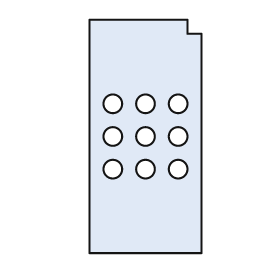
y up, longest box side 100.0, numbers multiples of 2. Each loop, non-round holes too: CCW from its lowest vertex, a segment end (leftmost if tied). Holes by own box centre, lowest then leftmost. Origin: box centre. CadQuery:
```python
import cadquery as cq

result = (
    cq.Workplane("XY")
    .moveTo(-24.0, -50.0)
    .lineTo(24.0, -50.0)
    .lineTo(24.0, 44.0)
    .lineTo(18.0, 44.0)
    .lineTo(18.0, 50.0)
    .lineTo(-24.0, 50.0)
    .close()
    .moveTo(-14.0, -14.0)
    .circle(4.0)
    .moveTo(0.0, -14.0)
    .circle(4.0)
    .moveTo(14.0, -14.0)
    .circle(4.0)
    .moveTo(-14.0, 0.0)
    .circle(4.0)
    .moveTo(0.0, 0.0)
    .circle(4.0)
    .moveTo(14.0, 0.0)
    .circle(4.0)
    .moveTo(-14.0, 14.0)
    .circle(4.0)
    .moveTo(0.0, 14.0)
    .circle(4.0)
    .moveTo(14.0, 14.0)
    .circle(4.0)
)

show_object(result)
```